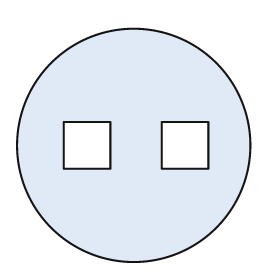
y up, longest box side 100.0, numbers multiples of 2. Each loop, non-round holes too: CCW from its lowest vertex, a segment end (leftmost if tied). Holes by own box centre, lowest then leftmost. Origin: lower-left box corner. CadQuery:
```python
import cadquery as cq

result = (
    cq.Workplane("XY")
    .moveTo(50.0, 50.0)
    .circle(50.0)
    .moveTo(20.0, 40.0)
    .lineTo(40.0, 40.0)
    .lineTo(40.0, 60.0)
    .lineTo(20.0, 60.0)
    .close()
    .moveTo(62.0, 40.0)
    .lineTo(82.0, 40.0)
    .lineTo(82.0, 60.0)
    .lineTo(62.0, 60.0)
    .close()
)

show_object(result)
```